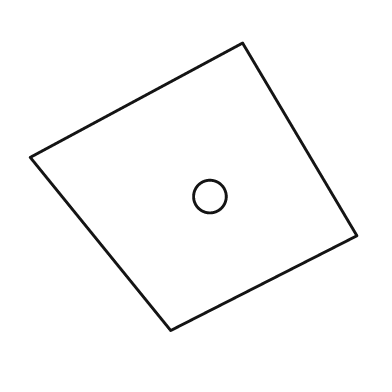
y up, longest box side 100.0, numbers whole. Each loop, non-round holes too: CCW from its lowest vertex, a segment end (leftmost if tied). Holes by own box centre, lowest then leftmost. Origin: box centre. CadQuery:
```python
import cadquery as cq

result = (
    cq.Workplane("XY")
    .moveTo(-7.0, -44.0)
    .lineTo(50.0, -15.0)
    .lineTo(15.0, 44.0)
    .lineTo(-50.0, 9.0)
    .close()
    .moveTo(5.0, -3.0)
    .circle(5.0)
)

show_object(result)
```